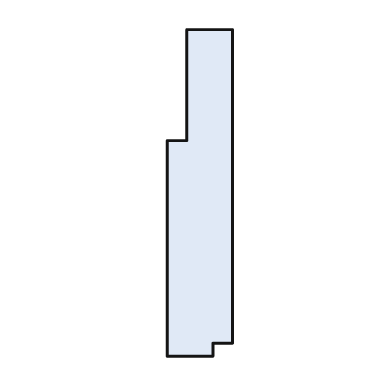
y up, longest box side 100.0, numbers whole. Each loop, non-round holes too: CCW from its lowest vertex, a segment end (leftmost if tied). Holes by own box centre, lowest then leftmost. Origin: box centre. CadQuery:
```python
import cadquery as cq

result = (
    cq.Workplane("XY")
    .moveTo(-10.0, -50.0)
    .lineTo(4.0, -50.0)
    .lineTo(4.0, -46.0)
    .lineTo(10.0, -46.0)
    .lineTo(10.0, 50.0)
    .lineTo(-4.0, 50.0)
    .lineTo(-4.0, 16.0)
    .lineTo(-10.0, 16.0)
    .close()
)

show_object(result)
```